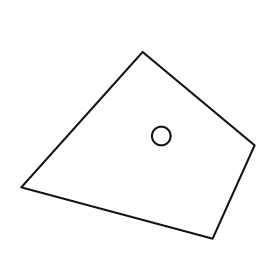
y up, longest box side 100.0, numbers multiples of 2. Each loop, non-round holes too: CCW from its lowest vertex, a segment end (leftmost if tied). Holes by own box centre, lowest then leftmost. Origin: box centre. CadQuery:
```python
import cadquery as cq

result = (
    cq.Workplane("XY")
    .moveTo(32.0, -40.0)
    .lineTo(50.0, 0.0)
    .lineTo(2.0, 40.0)
    .lineTo(-50.0, -18.0)
    .close()
    .moveTo(10.0, 4.0)
    .circle(4.0)
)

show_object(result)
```